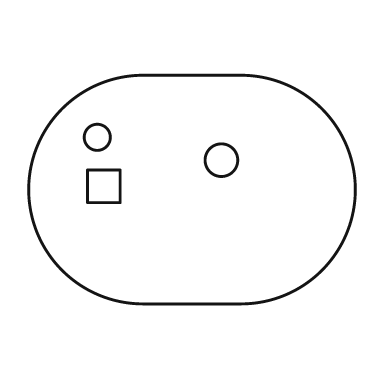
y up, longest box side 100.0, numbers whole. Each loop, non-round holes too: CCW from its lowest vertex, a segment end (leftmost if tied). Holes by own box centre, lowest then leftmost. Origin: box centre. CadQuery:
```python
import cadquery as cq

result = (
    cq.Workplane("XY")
    .moveTo(-15.0, -35.0)
    .lineTo(15.0, -35.0)
    .threePointArc((50.0, 0.0), (15.0, 35.0))
    .lineTo(-15.0, 35.0)
    .threePointArc((-50.0, 0.0), (-15.0, -35.0))
    .close()
    .moveTo(-32.0, -4.0)
    .lineTo(-22.0, -4.0)
    .lineTo(-22.0, 6.0)
    .lineTo(-32.0, 6.0)
    .close()
    .moveTo(9.0, 9.0)
    .circle(5.0)
    .moveTo(-29.0, 16.0)
    .circle(4.0)
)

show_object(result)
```